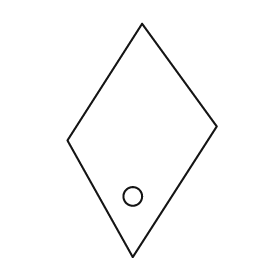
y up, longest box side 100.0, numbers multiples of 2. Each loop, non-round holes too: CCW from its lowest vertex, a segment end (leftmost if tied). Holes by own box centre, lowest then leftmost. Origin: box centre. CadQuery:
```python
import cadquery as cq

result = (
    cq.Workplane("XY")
    .moveTo(-4.0, -50.0)
    .lineTo(32.0, 6.0)
    .lineTo(0.0, 50.0)
    .lineTo(-32.0, 0.0)
    .close()
    .moveTo(-4.0, -24.0)
    .circle(4.0)
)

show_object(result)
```